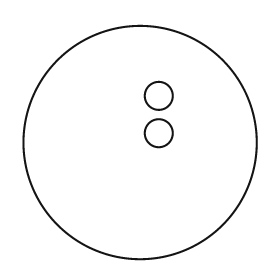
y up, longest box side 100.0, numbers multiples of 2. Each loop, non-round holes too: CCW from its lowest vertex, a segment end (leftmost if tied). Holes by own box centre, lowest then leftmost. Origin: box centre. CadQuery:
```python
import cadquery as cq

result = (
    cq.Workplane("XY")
    .moveTo(0.0, 0.0)
    .circle(50.0)
    .moveTo(8.0, 4.0)
    .circle(6.0)
    .moveTo(8.0, 20.0)
    .circle(6.0)
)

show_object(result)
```